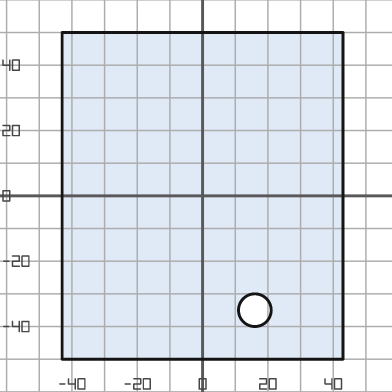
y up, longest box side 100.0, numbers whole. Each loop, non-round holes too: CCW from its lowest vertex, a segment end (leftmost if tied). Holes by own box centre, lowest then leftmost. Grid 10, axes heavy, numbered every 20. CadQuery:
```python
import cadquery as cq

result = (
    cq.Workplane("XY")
    .moveTo(-43.0, -50.0)
    .lineTo(43.0, -50.0)
    .lineTo(43.0, 50.0)
    .lineTo(-43.0, 50.0)
    .close()
    .moveTo(16.0, -35.0)
    .circle(5.0)
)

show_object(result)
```